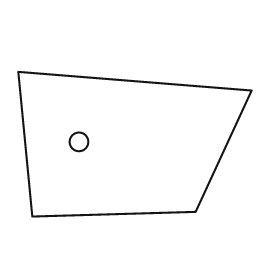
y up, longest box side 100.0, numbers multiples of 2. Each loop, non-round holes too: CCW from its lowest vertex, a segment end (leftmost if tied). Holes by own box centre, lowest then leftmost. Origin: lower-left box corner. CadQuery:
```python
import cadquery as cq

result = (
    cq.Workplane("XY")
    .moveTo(6.0, 0.0)
    .lineTo(76.0, 2.0)
    .lineTo(100.0, 54.0)
    .lineTo(0.0, 62.0)
    .close()
    .moveTo(26.0, 32.0)
    .circle(4.0)
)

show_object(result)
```